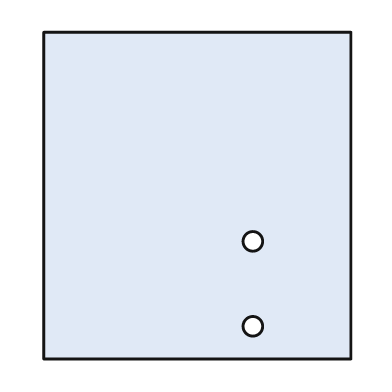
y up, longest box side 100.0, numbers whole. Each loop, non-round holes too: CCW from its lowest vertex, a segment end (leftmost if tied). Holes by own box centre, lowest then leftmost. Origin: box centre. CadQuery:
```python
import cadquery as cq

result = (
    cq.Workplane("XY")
    .moveTo(-47.0, -50.0)
    .lineTo(47.0, -50.0)
    .lineTo(47.0, 50.0)
    .lineTo(-47.0, 50.0)
    .close()
    .moveTo(17.0, -40.0)
    .circle(3.0)
    .moveTo(17.0, -14.0)
    .circle(3.0)
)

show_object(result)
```